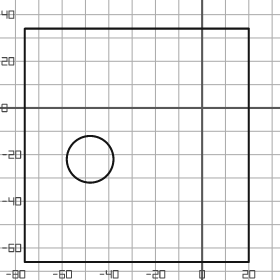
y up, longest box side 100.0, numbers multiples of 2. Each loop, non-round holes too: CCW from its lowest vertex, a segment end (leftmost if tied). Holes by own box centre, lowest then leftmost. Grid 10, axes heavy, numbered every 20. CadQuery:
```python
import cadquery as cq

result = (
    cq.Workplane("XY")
    .moveTo(-76.0, -66.0)
    .lineTo(20.0, -66.0)
    .lineTo(20.0, 34.0)
    .lineTo(-76.0, 34.0)
    .close()
    .moveTo(-48.0, -22.0)
    .circle(10.0)
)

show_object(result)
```